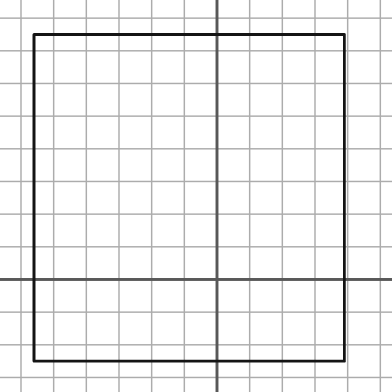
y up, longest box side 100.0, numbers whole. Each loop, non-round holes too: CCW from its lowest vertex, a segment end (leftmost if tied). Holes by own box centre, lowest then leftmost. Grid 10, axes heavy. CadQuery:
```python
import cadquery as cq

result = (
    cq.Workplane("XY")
    .moveTo(-56.0, -25.0)
    .lineTo(39.0, -25.0)
    .lineTo(39.0, 75.0)
    .lineTo(-56.0, 75.0)
    .close()
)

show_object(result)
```